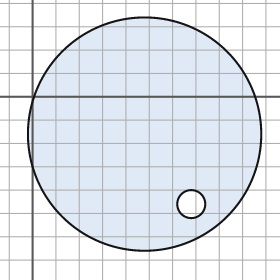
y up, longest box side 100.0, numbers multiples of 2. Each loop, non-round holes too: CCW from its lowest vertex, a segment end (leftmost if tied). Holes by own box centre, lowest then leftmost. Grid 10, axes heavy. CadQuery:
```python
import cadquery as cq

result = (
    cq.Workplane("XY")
    .moveTo(48.0, -16.0)
    .circle(50.0)
    .moveTo(68.0, -46.0)
    .circle(6.0)
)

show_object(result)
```